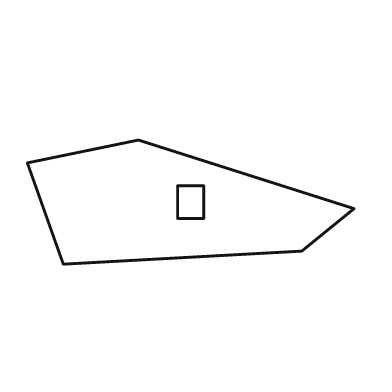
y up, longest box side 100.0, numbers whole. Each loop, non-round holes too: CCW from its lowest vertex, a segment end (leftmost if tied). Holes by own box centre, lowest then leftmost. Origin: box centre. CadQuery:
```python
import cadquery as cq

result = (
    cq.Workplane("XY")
    .moveTo(-39.0, -19.0)
    .lineTo(34.0, -15.0)
    .lineTo(50.0, -2.0)
    .lineTo(-16.0, 19.0)
    .lineTo(-50.0, 12.0)
    .close()
    .moveTo(-4.0, -5.0)
    .lineTo(4.0, -5.0)
    .lineTo(4.0, 5.0)
    .lineTo(-4.0, 5.0)
    .close()
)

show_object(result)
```